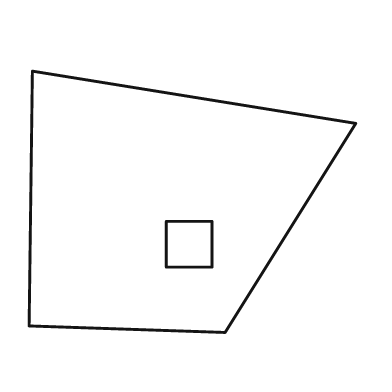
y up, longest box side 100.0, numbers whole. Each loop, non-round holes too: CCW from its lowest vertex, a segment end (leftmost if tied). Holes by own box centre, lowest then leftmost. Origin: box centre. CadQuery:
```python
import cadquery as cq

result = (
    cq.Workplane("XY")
    .moveTo(10.0, -40.0)
    .lineTo(50.0, 24.0)
    .lineTo(-49.0, 40.0)
    .lineTo(-50.0, -38.0)
    .close()
    .moveTo(-8.0, -20.0)
    .lineTo(6.0, -20.0)
    .lineTo(6.0, -6.0)
    .lineTo(-8.0, -6.0)
    .close()
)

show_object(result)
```